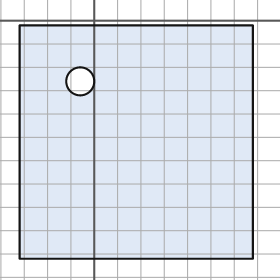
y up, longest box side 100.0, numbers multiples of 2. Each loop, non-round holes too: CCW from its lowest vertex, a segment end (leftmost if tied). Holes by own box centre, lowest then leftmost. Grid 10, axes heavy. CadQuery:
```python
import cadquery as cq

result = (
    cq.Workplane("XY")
    .moveTo(-32.0, -102.0)
    .lineTo(68.0, -102.0)
    .lineTo(68.0, -2.0)
    .lineTo(-32.0, -2.0)
    .close()
    .moveTo(-6.0, -26.0)
    .circle(6.0)
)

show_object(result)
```